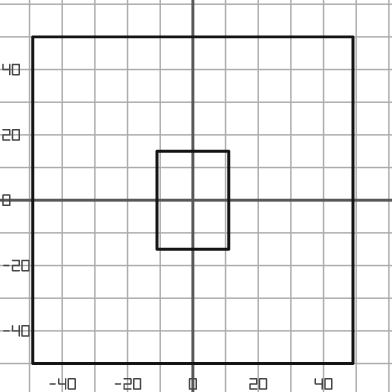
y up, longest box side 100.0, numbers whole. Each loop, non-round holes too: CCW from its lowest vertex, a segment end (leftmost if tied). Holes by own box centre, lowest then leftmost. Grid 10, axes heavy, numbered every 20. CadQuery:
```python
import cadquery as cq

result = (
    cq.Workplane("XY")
    .moveTo(-49.0, -50.0)
    .lineTo(49.0, -50.0)
    .lineTo(49.0, 50.0)
    .lineTo(-49.0, 50.0)
    .close()
    .moveTo(-11.0, -15.0)
    .lineTo(11.0, -15.0)
    .lineTo(11.0, 15.0)
    .lineTo(-11.0, 15.0)
    .close()
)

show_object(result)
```